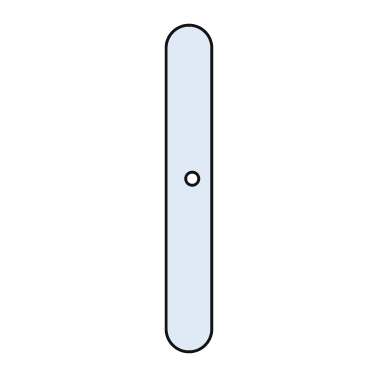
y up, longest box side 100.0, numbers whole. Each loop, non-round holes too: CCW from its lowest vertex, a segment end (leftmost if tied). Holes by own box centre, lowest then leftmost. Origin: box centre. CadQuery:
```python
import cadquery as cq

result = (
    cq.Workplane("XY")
    .moveTo(-7.0, -43.0)
    .threePointArc((0.0, -50.0), (7.0, -43.0))
    .lineTo(7.0, 43.0)
    .threePointArc((0.0, 50.0), (-7.0, 43.0))
    .close()
    .moveTo(1.0, 3.0)
    .circle(2.0)
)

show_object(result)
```